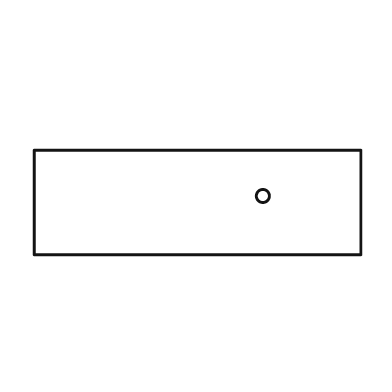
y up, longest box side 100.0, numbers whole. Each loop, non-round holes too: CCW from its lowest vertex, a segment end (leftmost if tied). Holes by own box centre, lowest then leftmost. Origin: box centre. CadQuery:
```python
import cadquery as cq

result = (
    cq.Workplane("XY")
    .moveTo(-50.0, -16.0)
    .lineTo(50.0, -16.0)
    .lineTo(50.0, 16.0)
    .lineTo(-50.0, 16.0)
    .close()
    .moveTo(20.0, 2.0)
    .circle(2.0)
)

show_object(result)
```